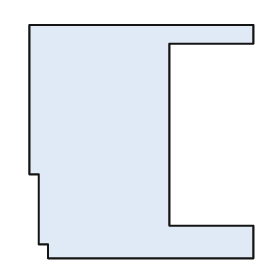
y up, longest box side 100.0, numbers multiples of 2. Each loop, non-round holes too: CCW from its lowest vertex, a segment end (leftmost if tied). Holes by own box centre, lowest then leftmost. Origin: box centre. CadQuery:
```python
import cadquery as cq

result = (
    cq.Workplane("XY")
    .moveTo(-40.0, -50.0)
    .lineTo(48.0, -50.0)
    .lineTo(48.0, -36.0)
    .lineTo(12.0, -36.0)
    .lineTo(12.0, 42.0)
    .lineTo(48.0, 42.0)
    .lineTo(48.0, 50.0)
    .lineTo(-48.0, 50.0)
    .lineTo(-48.0, -14.0)
    .lineTo(-44.0, -14.0)
    .lineTo(-44.0, -44.0)
    .lineTo(-40.0, -44.0)
    .close()
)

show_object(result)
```